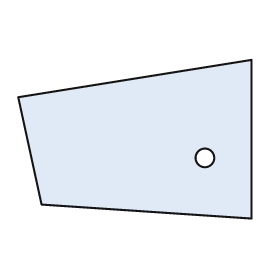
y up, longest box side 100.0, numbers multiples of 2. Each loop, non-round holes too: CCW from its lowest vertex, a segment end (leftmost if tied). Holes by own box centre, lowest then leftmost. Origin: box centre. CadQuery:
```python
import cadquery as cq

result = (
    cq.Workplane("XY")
    .moveTo(50.0, -34.0)
    .lineTo(50.0, 34.0)
    .lineTo(-50.0, 18.0)
    .lineTo(-40.0, -28.0)
    .close()
    .moveTo(30.0, -8.0)
    .circle(4.0)
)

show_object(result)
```